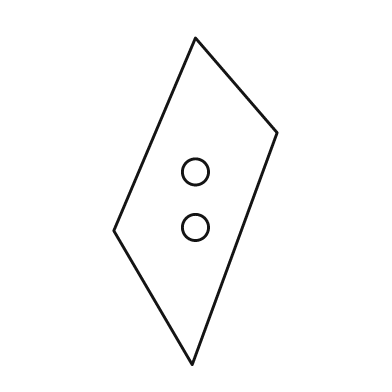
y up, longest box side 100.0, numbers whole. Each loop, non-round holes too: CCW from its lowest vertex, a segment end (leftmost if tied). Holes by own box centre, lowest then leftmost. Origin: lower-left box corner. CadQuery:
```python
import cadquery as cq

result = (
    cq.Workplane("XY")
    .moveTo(24.0, 0.0)
    .lineTo(50.0, 71.0)
    .lineTo(25.0, 100.0)
    .lineTo(0.0, 41.0)
    .close()
    .moveTo(25.0, 42.0)
    .circle(4.0)
    .moveTo(25.0, 59.0)
    .circle(4.0)
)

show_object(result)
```